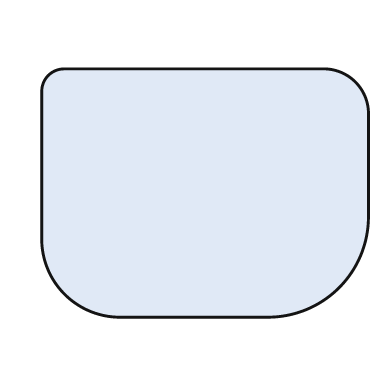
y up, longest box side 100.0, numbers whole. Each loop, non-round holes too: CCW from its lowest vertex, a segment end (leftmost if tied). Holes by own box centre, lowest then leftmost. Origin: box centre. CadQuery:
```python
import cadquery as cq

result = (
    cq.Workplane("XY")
    .moveTo(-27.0, -38.0)
    .lineTo(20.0, -38.0)
    .threePointArc((41.0, -29.0), (50.0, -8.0))
    .lineTo(50.0, 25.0)
    .threePointArc((46.0, 34.0), (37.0, 38.0))
    .lineTo(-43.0, 38.0)
    .threePointArc((-48.0, 36.0), (-50.0, 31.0))
    .lineTo(-50.0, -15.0)
    .threePointArc((-43.0, -31.0), (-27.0, -38.0))
    .close()
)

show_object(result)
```